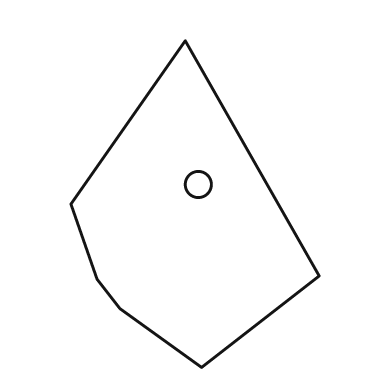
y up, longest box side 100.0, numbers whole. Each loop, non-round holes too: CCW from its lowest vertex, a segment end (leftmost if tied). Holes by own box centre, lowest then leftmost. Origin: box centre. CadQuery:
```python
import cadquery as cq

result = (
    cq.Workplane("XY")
    .moveTo(2.0, -50.0)
    .lineTo(38.0, -22.0)
    .lineTo(-3.0, 50.0)
    .lineTo(-38.0, 0.0)
    .lineTo(-30.0, -23.0)
    .lineTo(-23.0, -32.0)
    .close()
    .moveTo(1.0, 6.0)
    .circle(4.0)
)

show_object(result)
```